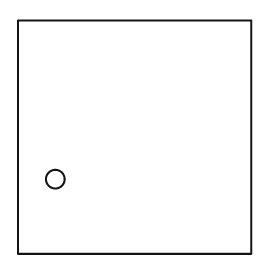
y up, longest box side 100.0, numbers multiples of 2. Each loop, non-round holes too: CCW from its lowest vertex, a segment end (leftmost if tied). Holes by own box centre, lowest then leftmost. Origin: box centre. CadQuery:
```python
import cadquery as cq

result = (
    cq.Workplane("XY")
    .moveTo(-50.0, -50.0)
    .lineTo(50.0, -50.0)
    .lineTo(50.0, 50.0)
    .lineTo(-50.0, 50.0)
    .close()
    .moveTo(-34.0, -18.0)
    .circle(4.0)
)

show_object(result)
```